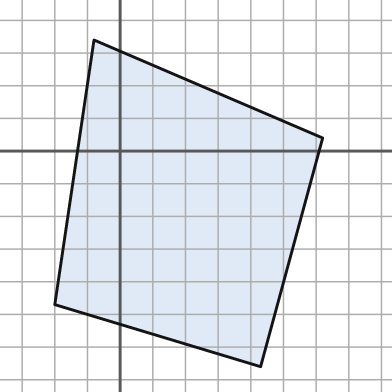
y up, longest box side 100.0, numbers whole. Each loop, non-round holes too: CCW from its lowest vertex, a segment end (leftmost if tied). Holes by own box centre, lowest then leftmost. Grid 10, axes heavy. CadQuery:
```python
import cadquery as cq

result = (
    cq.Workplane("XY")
    .moveTo(43.0, -66.0)
    .lineTo(62.0, 4.0)
    .lineTo(-8.0, 34.0)
    .lineTo(-20.0, -47.0)
    .close()
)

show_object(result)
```